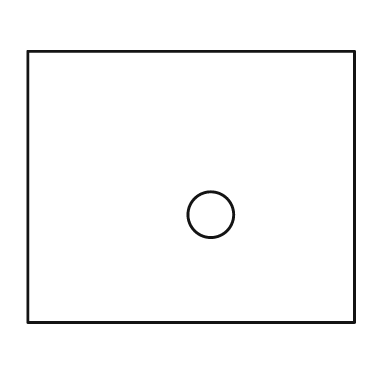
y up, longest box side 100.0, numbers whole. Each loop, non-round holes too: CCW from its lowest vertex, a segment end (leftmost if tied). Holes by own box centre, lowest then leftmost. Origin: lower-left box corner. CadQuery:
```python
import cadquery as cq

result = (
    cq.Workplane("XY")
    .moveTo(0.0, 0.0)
    .lineTo(100.0, 0.0)
    .lineTo(100.0, 83.0)
    .lineTo(0.0, 83.0)
    .close()
    .moveTo(56.0, 33.0)
    .circle(7.0)
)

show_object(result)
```